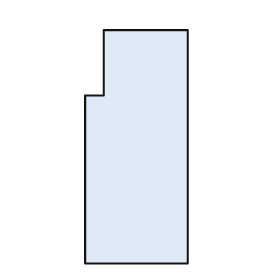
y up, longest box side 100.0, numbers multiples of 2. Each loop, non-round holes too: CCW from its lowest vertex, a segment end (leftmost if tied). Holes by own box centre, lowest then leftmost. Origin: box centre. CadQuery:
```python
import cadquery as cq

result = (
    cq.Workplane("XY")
    .moveTo(-22.0, -50.0)
    .lineTo(22.0, -50.0)
    .lineTo(22.0, 50.0)
    .lineTo(-14.0, 50.0)
    .lineTo(-14.0, 22.0)
    .lineTo(-22.0, 22.0)
    .close()
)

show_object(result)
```